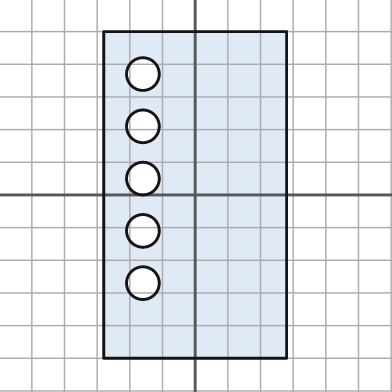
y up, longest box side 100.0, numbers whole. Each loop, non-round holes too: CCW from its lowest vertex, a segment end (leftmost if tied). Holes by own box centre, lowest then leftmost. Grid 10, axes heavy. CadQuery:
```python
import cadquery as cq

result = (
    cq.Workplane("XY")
    .moveTo(-28.0, -50.0)
    .lineTo(28.0, -50.0)
    .lineTo(28.0, 50.0)
    .lineTo(-28.0, 50.0)
    .close()
    .moveTo(-16.0, -27.0)
    .circle(5.0)
    .moveTo(-16.0, -11.0)
    .circle(5.0)
    .moveTo(-16.0, 5.0)
    .circle(5.0)
    .moveTo(-16.0, 21.0)
    .circle(5.0)
    .moveTo(-16.0, 37.0)
    .circle(5.0)
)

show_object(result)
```